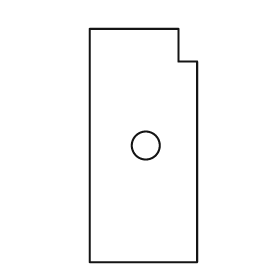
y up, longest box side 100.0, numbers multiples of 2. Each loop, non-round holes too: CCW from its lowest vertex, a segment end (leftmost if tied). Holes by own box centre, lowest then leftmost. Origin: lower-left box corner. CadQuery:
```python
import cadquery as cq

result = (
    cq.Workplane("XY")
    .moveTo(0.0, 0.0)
    .lineTo(46.0, 0.0)
    .lineTo(46.0, 86.0)
    .lineTo(38.0, 86.0)
    .lineTo(38.0, 100.0)
    .lineTo(0.0, 100.0)
    .close()
    .moveTo(24.0, 50.0)
    .circle(6.0)
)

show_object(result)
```